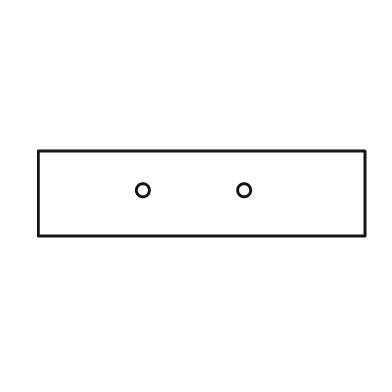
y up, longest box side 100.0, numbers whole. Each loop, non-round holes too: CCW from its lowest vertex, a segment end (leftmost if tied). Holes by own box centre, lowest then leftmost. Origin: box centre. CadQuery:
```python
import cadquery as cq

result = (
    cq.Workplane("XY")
    .moveTo(-50.0, -13.0)
    .lineTo(50.0, -13.0)
    .lineTo(50.0, 13.0)
    .lineTo(-50.0, 13.0)
    .close()
    .moveTo(-18.0, 1.0)
    .circle(2.0)
    .moveTo(13.0, 1.0)
    .circle(2.0)
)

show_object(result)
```